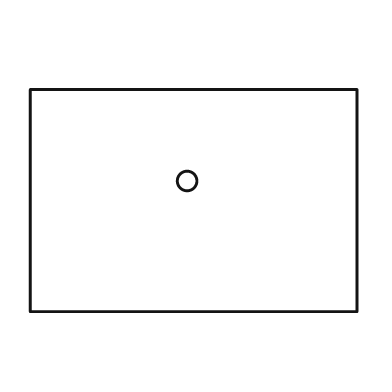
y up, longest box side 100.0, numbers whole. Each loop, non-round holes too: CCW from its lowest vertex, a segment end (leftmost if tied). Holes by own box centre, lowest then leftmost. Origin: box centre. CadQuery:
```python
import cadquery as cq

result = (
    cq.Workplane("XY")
    .moveTo(-50.0, -34.0)
    .lineTo(50.0, -34.0)
    .lineTo(50.0, 34.0)
    .lineTo(-50.0, 34.0)
    .close()
    .moveTo(-2.0, 6.0)
    .circle(3.0)
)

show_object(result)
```